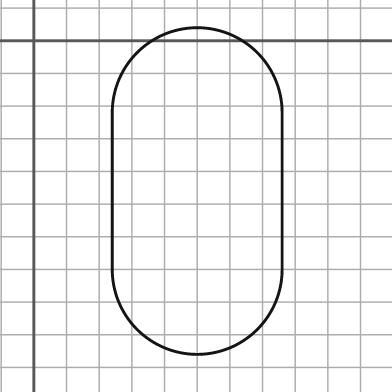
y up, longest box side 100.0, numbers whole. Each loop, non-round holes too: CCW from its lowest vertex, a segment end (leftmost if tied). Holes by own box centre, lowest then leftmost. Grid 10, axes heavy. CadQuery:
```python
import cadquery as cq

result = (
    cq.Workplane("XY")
    .moveTo(24.0, -70.0)
    .threePointArc((50.0, -96.0), (76.0, -70.0))
    .lineTo(76.0, -22.0)
    .threePointArc((50.0, 4.0), (24.0, -22.0))
    .close()
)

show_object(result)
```